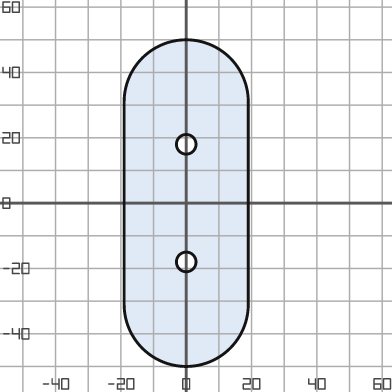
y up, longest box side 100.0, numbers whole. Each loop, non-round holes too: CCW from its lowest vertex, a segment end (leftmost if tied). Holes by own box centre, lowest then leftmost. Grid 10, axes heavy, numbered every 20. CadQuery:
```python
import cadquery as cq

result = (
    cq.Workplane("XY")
    .moveTo(-19.0, -31.0)
    .threePointArc((0.0, -50.0), (19.0, -31.0))
    .lineTo(19.0, 31.0)
    .threePointArc((0.0, 50.0), (-19.0, 31.0))
    .close()
    .moveTo(0.0, -18.0)
    .circle(3.0)
    .moveTo(0.0, 18.0)
    .circle(3.0)
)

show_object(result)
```